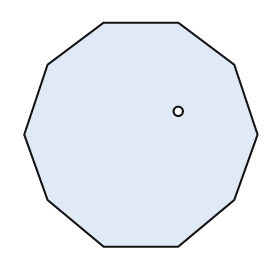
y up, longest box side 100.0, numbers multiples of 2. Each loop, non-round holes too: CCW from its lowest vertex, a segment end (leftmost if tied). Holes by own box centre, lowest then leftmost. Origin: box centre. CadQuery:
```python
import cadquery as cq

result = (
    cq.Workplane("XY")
    .moveTo(-16.0, -48.0)
    .lineTo(16.0, -48.0)
    .lineTo(40.0, -28.0)
    .lineTo(50.0, 0.0)
    .lineTo(40.0, 30.0)
    .lineTo(16.0, 48.0)
    .lineTo(-16.0, 48.0)
    .lineTo(-40.0, 30.0)
    .lineTo(-50.0, 0.0)
    .lineTo(-40.0, -28.0)
    .close()
    .moveTo(16.0, 10.0)
    .circle(2.0)
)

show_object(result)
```